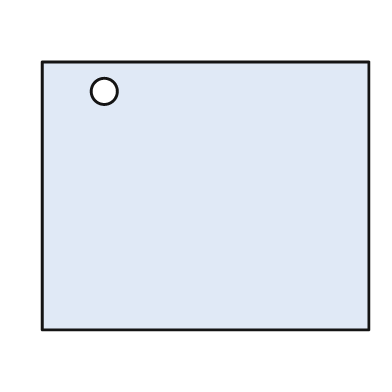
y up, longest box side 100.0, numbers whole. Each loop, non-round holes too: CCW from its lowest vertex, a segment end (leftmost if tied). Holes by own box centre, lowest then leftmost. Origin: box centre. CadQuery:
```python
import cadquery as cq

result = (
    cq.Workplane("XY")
    .moveTo(-50.0, -41.0)
    .lineTo(50.0, -41.0)
    .lineTo(50.0, 41.0)
    .lineTo(-50.0, 41.0)
    .close()
    .moveTo(-31.0, 32.0)
    .circle(4.0)
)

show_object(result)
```